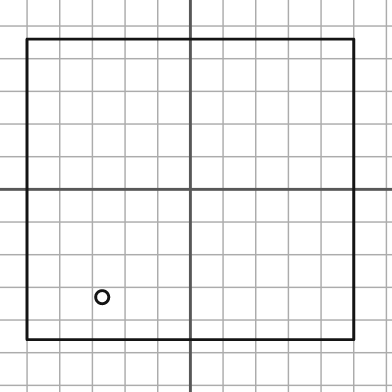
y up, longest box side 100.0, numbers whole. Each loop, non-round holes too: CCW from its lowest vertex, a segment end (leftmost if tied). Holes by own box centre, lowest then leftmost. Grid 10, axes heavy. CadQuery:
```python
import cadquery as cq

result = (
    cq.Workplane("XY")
    .moveTo(-50.0, -46.0)
    .lineTo(50.0, -46.0)
    .lineTo(50.0, 46.0)
    .lineTo(-50.0, 46.0)
    .close()
    .moveTo(-27.0, -33.0)
    .circle(2.0)
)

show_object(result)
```